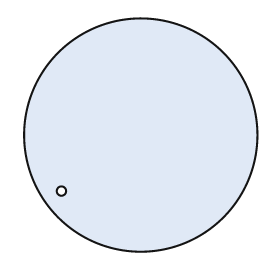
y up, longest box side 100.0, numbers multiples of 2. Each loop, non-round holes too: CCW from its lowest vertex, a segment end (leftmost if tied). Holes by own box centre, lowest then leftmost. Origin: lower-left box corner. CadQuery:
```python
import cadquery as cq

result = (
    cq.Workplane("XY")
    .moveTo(50.0, 50.0)
    .circle(50.0)
    .moveTo(16.0, 26.0)
    .circle(2.0)
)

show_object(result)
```